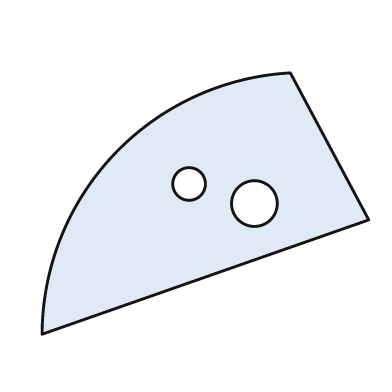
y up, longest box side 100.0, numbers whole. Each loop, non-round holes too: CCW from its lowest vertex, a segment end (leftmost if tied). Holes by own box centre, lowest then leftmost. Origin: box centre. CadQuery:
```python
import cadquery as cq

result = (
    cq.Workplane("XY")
    .moveTo(-50.0, -40.0)
    .lineTo(50.0, -5.0)
    .lineTo(26.0, 40.0)
    .threePointArc((-28.0, 15.0), (-50.0, -40.0))
    .close()
    .moveTo(15.0, 0.0)
    .circle(7.0)
    .moveTo(-5.0, 6.0)
    .circle(5.0)
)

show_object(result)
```